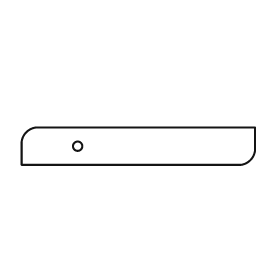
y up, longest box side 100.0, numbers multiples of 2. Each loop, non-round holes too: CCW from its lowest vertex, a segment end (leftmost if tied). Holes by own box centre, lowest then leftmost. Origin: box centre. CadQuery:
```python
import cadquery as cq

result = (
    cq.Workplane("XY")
    .moveTo(-50.0, -8.0)
    .lineTo(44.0, -8.0)
    .threePointArc((48.0, -6.0), (50.0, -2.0))
    .lineTo(50.0, 8.0)
    .lineTo(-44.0, 8.0)
    .threePointArc((-48.0, 6.0), (-50.0, 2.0))
    .close()
    .moveTo(-26.0, 0.0)
    .circle(2.0)
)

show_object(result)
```